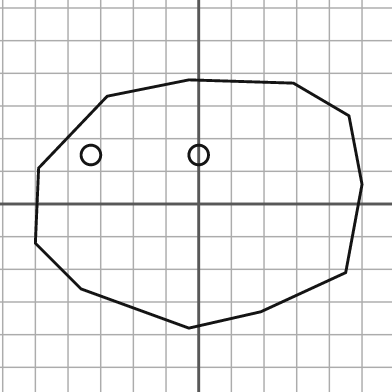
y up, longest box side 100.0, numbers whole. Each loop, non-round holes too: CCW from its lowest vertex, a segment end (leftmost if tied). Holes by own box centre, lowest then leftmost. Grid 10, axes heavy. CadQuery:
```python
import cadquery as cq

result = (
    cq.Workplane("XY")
    .moveTo(-3.0, -38.0)
    .lineTo(19.0, -33.0)
    .lineTo(45.0, -21.0)
    .lineTo(50.0, 6.0)
    .lineTo(46.0, 27.0)
    .lineTo(29.0, 37.0)
    .lineTo(-3.0, 38.0)
    .lineTo(-28.0, 33.0)
    .lineTo(-49.0, 11.0)
    .lineTo(-50.0, -12.0)
    .lineTo(-36.0, -26.0)
    .close()
    .moveTo(-33.0, 15.0)
    .circle(3.0)
    .moveTo(0.0, 15.0)
    .circle(3.0)
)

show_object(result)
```